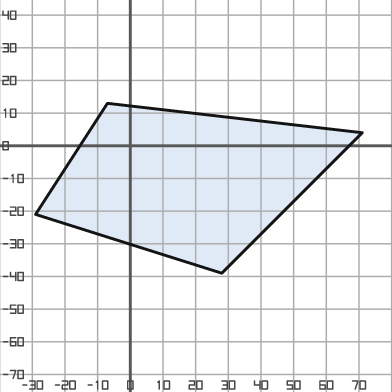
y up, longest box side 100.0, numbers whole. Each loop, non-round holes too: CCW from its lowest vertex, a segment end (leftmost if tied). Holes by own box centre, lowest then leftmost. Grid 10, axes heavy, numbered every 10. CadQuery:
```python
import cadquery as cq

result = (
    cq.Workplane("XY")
    .moveTo(28.0, -39.0)
    .lineTo(71.0, 4.0)
    .lineTo(-7.0, 13.0)
    .lineTo(-29.0, -21.0)
    .close()
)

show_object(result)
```